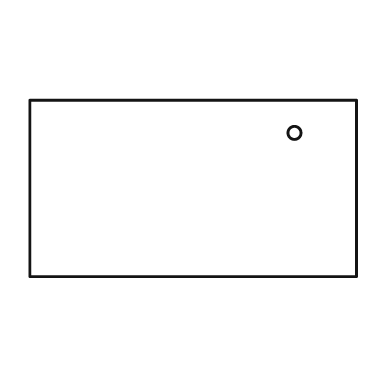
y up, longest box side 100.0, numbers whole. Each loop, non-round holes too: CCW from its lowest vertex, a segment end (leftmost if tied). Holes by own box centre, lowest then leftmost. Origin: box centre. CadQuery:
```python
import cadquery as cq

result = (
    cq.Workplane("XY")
    .moveTo(-50.0, -27.0)
    .lineTo(50.0, -27.0)
    .lineTo(50.0, 27.0)
    .lineTo(-50.0, 27.0)
    .close()
    .moveTo(31.0, 17.0)
    .circle(2.0)
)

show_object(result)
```